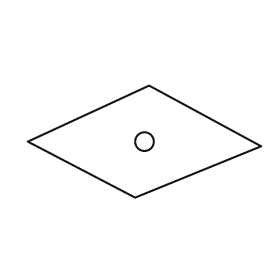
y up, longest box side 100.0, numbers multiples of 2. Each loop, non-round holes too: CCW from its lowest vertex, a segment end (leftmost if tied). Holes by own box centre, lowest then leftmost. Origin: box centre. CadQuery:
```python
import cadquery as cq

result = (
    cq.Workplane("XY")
    .moveTo(-4.0, -24.0)
    .lineTo(50.0, -2.0)
    .lineTo(2.0, 24.0)
    .lineTo(-50.0, 0.0)
    .close()
    .moveTo(0.0, 0.0)
    .circle(4.0)
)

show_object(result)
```